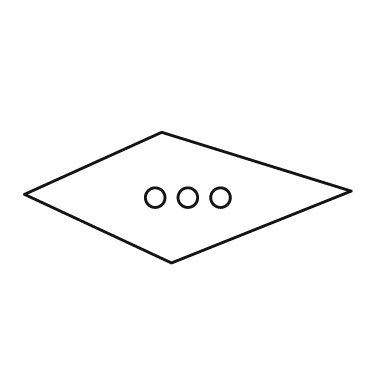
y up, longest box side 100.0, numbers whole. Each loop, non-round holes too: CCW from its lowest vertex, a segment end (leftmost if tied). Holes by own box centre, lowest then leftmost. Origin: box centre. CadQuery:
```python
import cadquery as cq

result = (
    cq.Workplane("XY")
    .moveTo(-5.0, -20.0)
    .lineTo(50.0, 2.0)
    .lineTo(-8.0, 20.0)
    .lineTo(-50.0, 1.0)
    .close()
    .moveTo(-10.0, 0.0)
    .circle(3.0)
    .moveTo(0.0, 0.0)
    .circle(3.0)
    .moveTo(10.0, 0.0)
    .circle(3.0)
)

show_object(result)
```